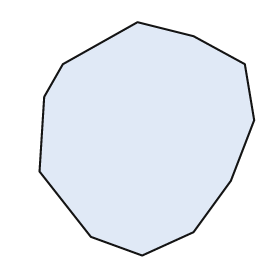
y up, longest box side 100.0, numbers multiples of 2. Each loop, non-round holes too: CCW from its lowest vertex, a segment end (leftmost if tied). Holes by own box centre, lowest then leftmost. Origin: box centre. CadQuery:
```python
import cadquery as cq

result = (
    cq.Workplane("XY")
    .moveTo(-2.0, -50.0)
    .lineTo(20.0, -40.0)
    .lineTo(36.0, -18.0)
    .lineTo(46.0, 8.0)
    .lineTo(42.0, 32.0)
    .lineTo(20.0, 44.0)
    .lineTo(-4.0, 50.0)
    .lineTo(-36.0, 32.0)
    .lineTo(-44.0, 18.0)
    .lineTo(-46.0, -14.0)
    .lineTo(-24.0, -42.0)
    .close()
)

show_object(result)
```